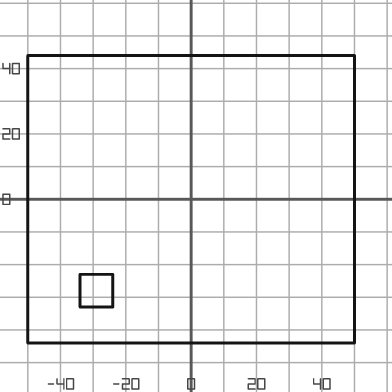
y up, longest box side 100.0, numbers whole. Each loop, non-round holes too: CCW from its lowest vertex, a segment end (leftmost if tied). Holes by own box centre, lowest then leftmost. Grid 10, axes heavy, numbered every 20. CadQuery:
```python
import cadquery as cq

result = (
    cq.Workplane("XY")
    .moveTo(-50.0, -44.0)
    .lineTo(50.0, -44.0)
    .lineTo(50.0, 44.0)
    .lineTo(-50.0, 44.0)
    .close()
    .moveTo(-34.0, -33.0)
    .lineTo(-24.0, -33.0)
    .lineTo(-24.0, -23.0)
    .lineTo(-34.0, -23.0)
    .close()
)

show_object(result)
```